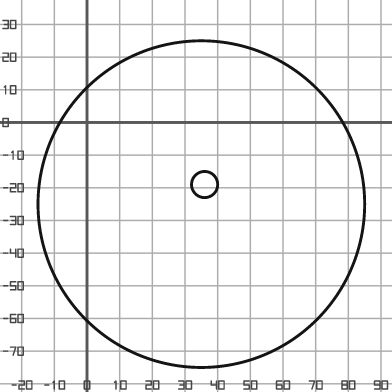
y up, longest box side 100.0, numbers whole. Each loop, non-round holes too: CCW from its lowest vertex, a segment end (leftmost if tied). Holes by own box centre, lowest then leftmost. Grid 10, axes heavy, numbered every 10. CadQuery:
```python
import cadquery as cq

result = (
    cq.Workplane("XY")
    .moveTo(35.0, -25.0)
    .circle(50.0)
    .moveTo(36.0, -19.0)
    .circle(4.0)
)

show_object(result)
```